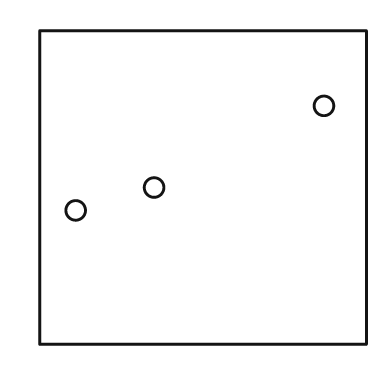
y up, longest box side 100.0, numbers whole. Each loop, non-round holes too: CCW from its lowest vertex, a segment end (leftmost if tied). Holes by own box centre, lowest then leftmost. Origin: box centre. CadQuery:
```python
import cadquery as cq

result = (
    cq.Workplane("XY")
    .moveTo(-50.0, -48.0)
    .lineTo(50.0, -48.0)
    .lineTo(50.0, 48.0)
    .lineTo(-50.0, 48.0)
    .close()
    .moveTo(-39.0, -7.0)
    .circle(3.0)
    .moveTo(-15.0, 0.0)
    .circle(3.0)
    .moveTo(37.0, 25.0)
    .circle(3.0)
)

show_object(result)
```